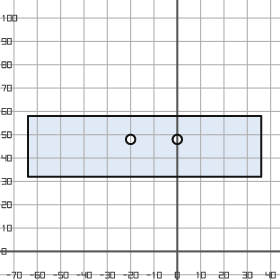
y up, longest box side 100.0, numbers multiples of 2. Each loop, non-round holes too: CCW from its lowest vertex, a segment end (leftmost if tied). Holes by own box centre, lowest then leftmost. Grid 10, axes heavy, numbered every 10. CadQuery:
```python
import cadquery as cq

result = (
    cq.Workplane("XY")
    .moveTo(-64.0, 32.0)
    .lineTo(36.0, 32.0)
    .lineTo(36.0, 58.0)
    .lineTo(-64.0, 58.0)
    .close()
    .moveTo(-20.0, 48.0)
    .circle(2.0)
    .moveTo(0.0, 48.0)
    .circle(2.0)
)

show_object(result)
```